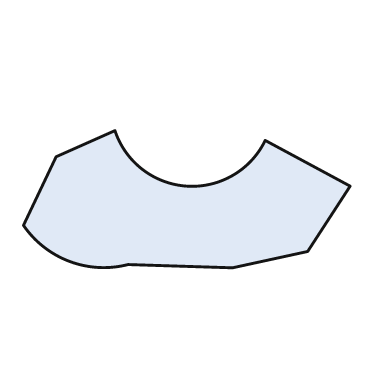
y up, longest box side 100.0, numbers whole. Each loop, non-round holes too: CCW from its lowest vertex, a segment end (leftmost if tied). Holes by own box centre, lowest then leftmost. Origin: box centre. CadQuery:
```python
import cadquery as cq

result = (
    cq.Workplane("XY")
    .moveTo(14.0, -21.0)
    .lineTo(37.0, -16.0)
    .lineTo(50.0, 4.0)
    .lineTo(24.0, 18.0)
    .threePointArc((0.0, 4.0), (-22.0, 21.0))
    .lineTo(-40.0, 13.0)
    .lineTo(-50.0, -8.0)
    .threePointArc((-36.0, -19.0), (-18.0, -20.0))
    .close()
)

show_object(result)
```